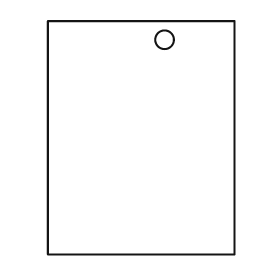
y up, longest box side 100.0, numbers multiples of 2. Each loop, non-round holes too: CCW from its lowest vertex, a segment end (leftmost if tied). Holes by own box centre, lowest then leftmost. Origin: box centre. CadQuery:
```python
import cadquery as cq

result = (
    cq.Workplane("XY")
    .moveTo(-40.0, -50.0)
    .lineTo(40.0, -50.0)
    .lineTo(40.0, 50.0)
    .lineTo(-40.0, 50.0)
    .close()
    .moveTo(10.0, 42.0)
    .circle(4.0)
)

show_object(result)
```